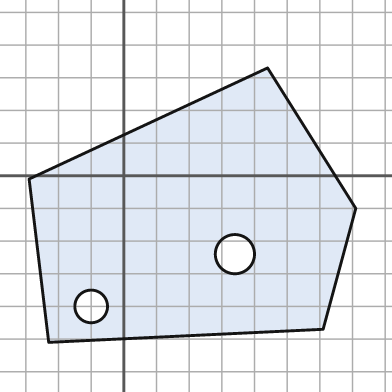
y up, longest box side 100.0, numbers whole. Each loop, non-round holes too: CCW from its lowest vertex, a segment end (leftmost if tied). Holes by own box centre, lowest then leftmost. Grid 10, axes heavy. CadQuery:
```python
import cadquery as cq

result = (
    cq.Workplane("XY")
    .moveTo(-23.0, -51.0)
    .lineTo(61.0, -47.0)
    .lineTo(71.0, -10.0)
    .lineTo(44.0, 33.0)
    .lineTo(-29.0, -1.0)
    .close()
    .moveTo(-10.0, -40.0)
    .circle(5.0)
    .moveTo(34.0, -24.0)
    .circle(6.0)
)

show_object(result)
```